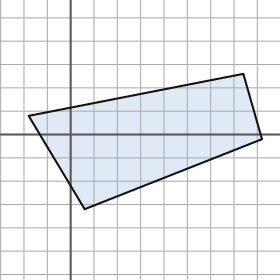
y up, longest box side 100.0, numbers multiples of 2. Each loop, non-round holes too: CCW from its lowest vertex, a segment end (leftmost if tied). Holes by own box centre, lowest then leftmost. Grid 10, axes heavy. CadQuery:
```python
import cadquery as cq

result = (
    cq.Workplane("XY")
    .moveTo(6.0, -32.0)
    .lineTo(82.0, -2.0)
    .lineTo(74.0, 26.0)
    .lineTo(-18.0, 8.0)
    .close()
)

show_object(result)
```